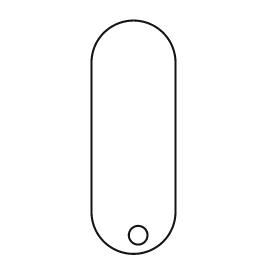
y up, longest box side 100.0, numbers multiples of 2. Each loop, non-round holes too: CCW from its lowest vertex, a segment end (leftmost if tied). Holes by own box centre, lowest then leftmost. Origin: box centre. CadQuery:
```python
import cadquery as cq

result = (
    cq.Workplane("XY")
    .moveTo(-18.0, -32.0)
    .threePointArc((0.0, -50.0), (18.0, -32.0))
    .lineTo(18.0, 32.0)
    .threePointArc((0.0, 50.0), (-18.0, 32.0))
    .close()
    .moveTo(2.0, -42.0)
    .circle(4.0)
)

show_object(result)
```